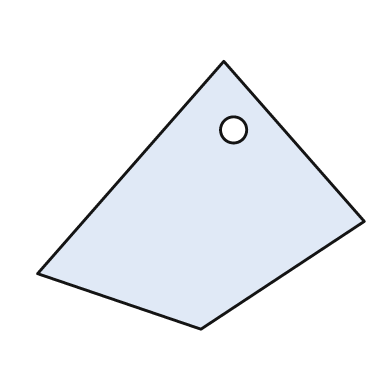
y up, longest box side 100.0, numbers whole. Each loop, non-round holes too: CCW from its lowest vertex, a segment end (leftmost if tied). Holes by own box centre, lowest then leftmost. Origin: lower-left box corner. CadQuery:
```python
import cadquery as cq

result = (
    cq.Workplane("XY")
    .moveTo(50.0, 0.0)
    .lineTo(100.0, 33.0)
    .lineTo(57.0, 82.0)
    .lineTo(0.0, 17.0)
    .close()
    .moveTo(60.0, 61.0)
    .circle(4.0)
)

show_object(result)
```